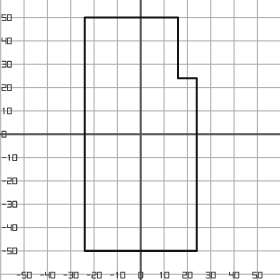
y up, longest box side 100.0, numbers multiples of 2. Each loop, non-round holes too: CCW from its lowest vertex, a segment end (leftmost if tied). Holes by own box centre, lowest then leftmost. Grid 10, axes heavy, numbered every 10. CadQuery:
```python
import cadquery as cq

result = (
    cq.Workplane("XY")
    .moveTo(-24.0, -50.0)
    .lineTo(24.0, -50.0)
    .lineTo(24.0, 24.0)
    .lineTo(16.0, 24.0)
    .lineTo(16.0, 50.0)
    .lineTo(-24.0, 50.0)
    .close()
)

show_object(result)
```